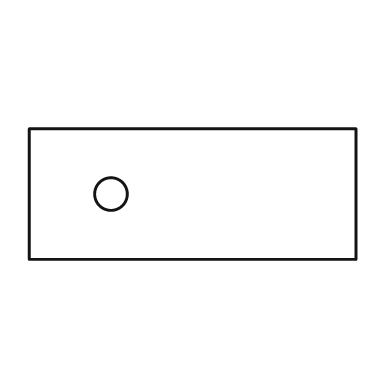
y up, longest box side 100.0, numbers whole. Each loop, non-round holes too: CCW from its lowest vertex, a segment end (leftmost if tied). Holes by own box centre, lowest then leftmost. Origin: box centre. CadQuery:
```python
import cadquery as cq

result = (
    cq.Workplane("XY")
    .moveTo(-50.0, -20.0)
    .lineTo(50.0, -20.0)
    .lineTo(50.0, 20.0)
    .lineTo(-50.0, 20.0)
    .close()
    .moveTo(-25.0, 0.0)
    .circle(5.0)
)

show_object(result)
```